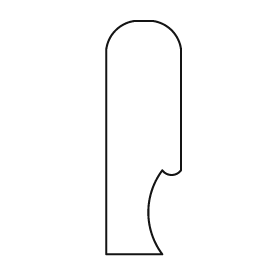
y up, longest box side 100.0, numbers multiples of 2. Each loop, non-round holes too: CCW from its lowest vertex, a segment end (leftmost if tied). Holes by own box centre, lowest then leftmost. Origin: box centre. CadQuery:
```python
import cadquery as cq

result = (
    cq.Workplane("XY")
    .moveTo(-16.0, -50.0)
    .lineTo(8.0, -50.0)
    .threePointArc((2.0, -32.0), (8.0, -14.0))
    .threePointArc((12.0, -16.0), (16.0, -14.0))
    .lineTo(16.0, 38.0)
    .threePointArc((12.0, 46.0), (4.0, 50.0))
    .lineTo(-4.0, 50.0)
    .threePointArc((-12.0, 46.0), (-16.0, 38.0))
    .close()
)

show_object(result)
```